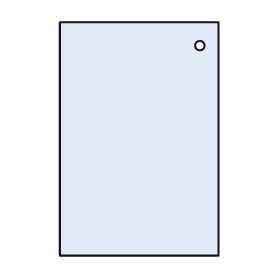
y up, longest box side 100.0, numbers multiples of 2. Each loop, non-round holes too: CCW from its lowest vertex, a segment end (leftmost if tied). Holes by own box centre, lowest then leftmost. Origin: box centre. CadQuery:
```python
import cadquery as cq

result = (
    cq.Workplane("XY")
    .moveTo(-34.0, -50.0)
    .lineTo(34.0, -50.0)
    .lineTo(34.0, 50.0)
    .lineTo(-34.0, 50.0)
    .close()
    .moveTo(26.0, 40.0)
    .circle(2.0)
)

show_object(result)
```